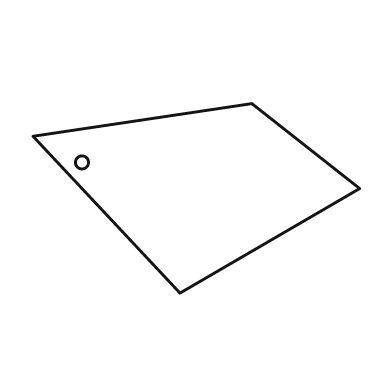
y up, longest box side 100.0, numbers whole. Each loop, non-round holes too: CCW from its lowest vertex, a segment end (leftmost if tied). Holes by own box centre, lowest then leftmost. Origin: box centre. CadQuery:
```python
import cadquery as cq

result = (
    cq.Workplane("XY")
    .moveTo(-5.0, -29.0)
    .lineTo(50.0, 3.0)
    .lineTo(17.0, 29.0)
    .lineTo(-50.0, 19.0)
    .close()
    .moveTo(-35.0, 11.0)
    .circle(2.0)
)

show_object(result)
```